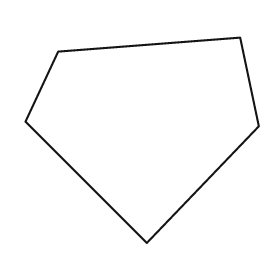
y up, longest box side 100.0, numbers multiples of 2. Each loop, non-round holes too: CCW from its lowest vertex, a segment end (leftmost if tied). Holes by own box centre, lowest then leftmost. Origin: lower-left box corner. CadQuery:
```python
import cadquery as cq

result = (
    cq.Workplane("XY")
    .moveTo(52.0, 0.0)
    .lineTo(100.0, 50.0)
    .lineTo(92.0, 88.0)
    .lineTo(14.0, 82.0)
    .lineTo(0.0, 52.0)
    .close()
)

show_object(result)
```